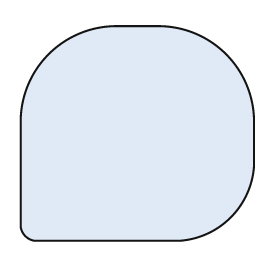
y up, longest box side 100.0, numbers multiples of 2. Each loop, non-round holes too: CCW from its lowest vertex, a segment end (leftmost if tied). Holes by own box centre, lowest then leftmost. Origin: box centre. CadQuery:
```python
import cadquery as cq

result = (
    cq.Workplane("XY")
    .moveTo(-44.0, -46.0)
    .lineTo(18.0, -46.0)
    .threePointArc((40.0, -36.0), (50.0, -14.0))
    .lineTo(50.0, 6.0)
    .threePointArc((38.0, 34.0), (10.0, 46.0))
    .lineTo(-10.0, 46.0)
    .threePointArc((-38.0, 34.0), (-50.0, 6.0))
    .lineTo(-50.0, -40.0)
    .threePointArc((-48.0, -44.0), (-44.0, -46.0))
    .close()
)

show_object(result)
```